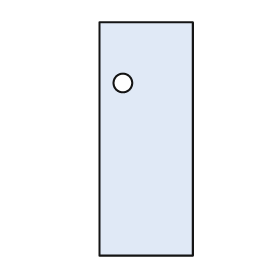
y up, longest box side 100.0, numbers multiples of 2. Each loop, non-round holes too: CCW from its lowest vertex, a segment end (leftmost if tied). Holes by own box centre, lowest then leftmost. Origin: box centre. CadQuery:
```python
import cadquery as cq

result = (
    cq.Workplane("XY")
    .moveTo(-20.0, -50.0)
    .lineTo(20.0, -50.0)
    .lineTo(20.0, 50.0)
    .lineTo(-20.0, 50.0)
    .close()
    .moveTo(-10.0, 24.0)
    .circle(4.0)
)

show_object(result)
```